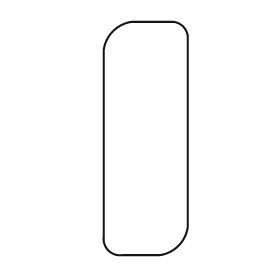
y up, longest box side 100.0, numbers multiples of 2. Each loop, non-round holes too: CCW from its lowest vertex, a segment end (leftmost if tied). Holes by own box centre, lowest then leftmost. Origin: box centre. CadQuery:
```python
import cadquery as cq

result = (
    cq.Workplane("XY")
    .moveTo(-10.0, -50.0)
    .lineTo(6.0, -50.0)
    .threePointArc((14.0, -46.0), (18.0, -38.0))
    .lineTo(18.0, 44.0)
    .threePointArc((16.0, 48.0), (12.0, 50.0))
    .lineTo(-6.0, 50.0)
    .threePointArc((-14.0, 46.0), (-18.0, 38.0))
    .lineTo(-18.0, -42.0)
    .threePointArc((-16.0, -48.0), (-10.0, -50.0))
    .close()
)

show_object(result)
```